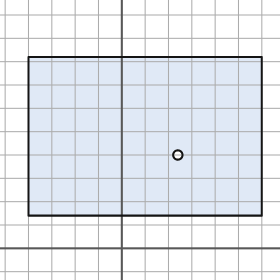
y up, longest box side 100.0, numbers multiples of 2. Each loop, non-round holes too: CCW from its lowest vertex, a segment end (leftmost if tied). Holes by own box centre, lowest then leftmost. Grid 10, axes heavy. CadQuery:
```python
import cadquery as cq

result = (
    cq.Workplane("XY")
    .moveTo(-40.0, 14.0)
    .lineTo(60.0, 14.0)
    .lineTo(60.0, 82.0)
    .lineTo(-40.0, 82.0)
    .close()
    .moveTo(24.0, 40.0)
    .circle(2.0)
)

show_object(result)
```